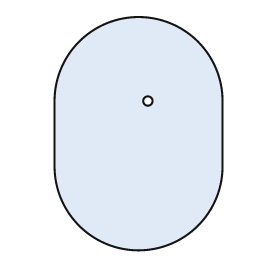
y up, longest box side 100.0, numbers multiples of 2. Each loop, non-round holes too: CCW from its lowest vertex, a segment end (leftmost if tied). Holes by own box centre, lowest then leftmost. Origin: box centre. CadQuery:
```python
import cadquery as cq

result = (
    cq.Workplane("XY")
    .moveTo(-36.0, -14.0)
    .threePointArc((0.0, -50.0), (36.0, -14.0))
    .lineTo(36.0, 14.0)
    .threePointArc((0.0, 50.0), (-36.0, 14.0))
    .close()
    .moveTo(4.0, 14.0)
    .circle(2.0)
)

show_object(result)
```